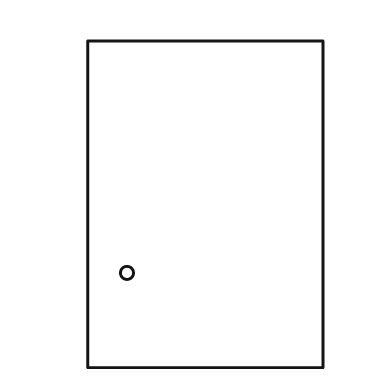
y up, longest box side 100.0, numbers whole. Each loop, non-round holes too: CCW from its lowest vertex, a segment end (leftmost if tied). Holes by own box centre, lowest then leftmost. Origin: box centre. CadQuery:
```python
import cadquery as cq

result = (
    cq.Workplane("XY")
    .moveTo(-36.0, -50.0)
    .lineTo(36.0, -50.0)
    .lineTo(36.0, 50.0)
    .lineTo(-36.0, 50.0)
    .close()
    .moveTo(-24.0, -21.0)
    .circle(2.0)
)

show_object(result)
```